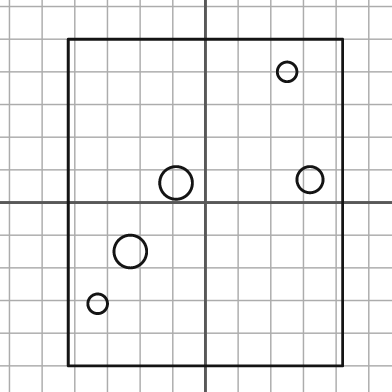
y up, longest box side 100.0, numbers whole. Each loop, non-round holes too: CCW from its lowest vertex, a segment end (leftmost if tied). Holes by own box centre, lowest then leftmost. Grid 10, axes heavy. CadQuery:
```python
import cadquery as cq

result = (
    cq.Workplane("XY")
    .moveTo(-42.0, -50.0)
    .lineTo(42.0, -50.0)
    .lineTo(42.0, 50.0)
    .lineTo(-42.0, 50.0)
    .close()
    .moveTo(-33.0, -31.0)
    .circle(3.0)
    .moveTo(-23.0, -15.0)
    .circle(5.0)
    .moveTo(-9.0, 6.0)
    .circle(5.0)
    .moveTo(32.0, 7.0)
    .circle(4.0)
    .moveTo(25.0, 40.0)
    .circle(3.0)
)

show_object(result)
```